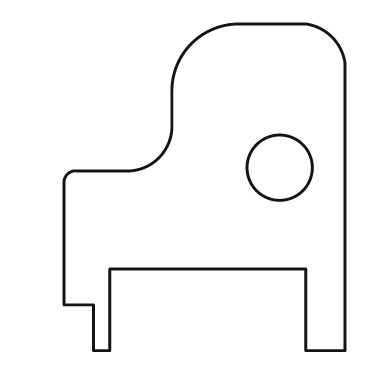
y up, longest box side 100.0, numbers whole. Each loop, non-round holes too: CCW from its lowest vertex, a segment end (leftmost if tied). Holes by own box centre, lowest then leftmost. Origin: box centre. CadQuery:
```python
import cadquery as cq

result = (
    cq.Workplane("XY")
    .moveTo(-34.0, -50.0)
    .lineTo(-29.0, -50.0)
    .lineTo(-29.0, -25.0)
    .lineTo(31.0, -25.0)
    .lineTo(31.0, -50.0)
    .lineTo(43.0, -50.0)
    .lineTo(43.0, 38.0)
    .threePointArc((39.0, 46.0), (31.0, 50.0))
    .lineTo(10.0, 50.0)
    .threePointArc((-4.0, 44.0), (-10.0, 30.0))
    .lineTo(-10.0, 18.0)
    .threePointArc((-14.0, 9.0), (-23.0, 5.0))
    .lineTo(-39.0, 5.0)
    .threePointArc((-42.0, 4.0), (-43.0, 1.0))
    .lineTo(-43.0, -36.0)
    .lineTo(-34.0, -36.0)
    .close()
    .moveTo(23.0, 6.0)
    .circle(10.0)
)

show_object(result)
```